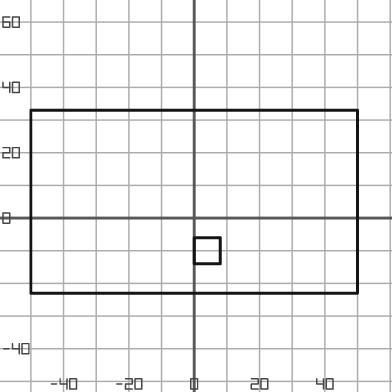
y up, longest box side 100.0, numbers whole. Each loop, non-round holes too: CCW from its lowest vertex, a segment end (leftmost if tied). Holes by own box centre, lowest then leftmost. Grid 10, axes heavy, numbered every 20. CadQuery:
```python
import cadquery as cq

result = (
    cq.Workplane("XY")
    .moveTo(-50.0, -23.0)
    .lineTo(50.0, -23.0)
    .lineTo(50.0, 33.0)
    .lineTo(-50.0, 33.0)
    .close()
    .moveTo(0.0, -14.0)
    .lineTo(8.0, -14.0)
    .lineTo(8.0, -6.0)
    .lineTo(0.0, -6.0)
    .close()
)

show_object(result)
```